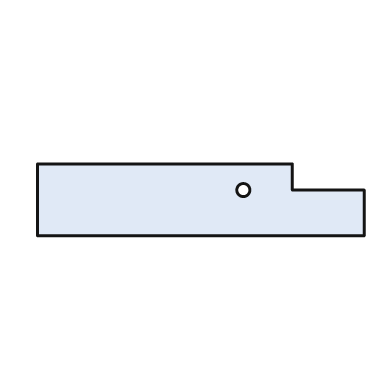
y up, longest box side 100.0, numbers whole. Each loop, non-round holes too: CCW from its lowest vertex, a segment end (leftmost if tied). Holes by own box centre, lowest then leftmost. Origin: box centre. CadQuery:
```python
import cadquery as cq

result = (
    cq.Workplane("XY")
    .moveTo(-50.0, -11.0)
    .lineTo(50.0, -11.0)
    .lineTo(50.0, 3.0)
    .lineTo(28.0, 3.0)
    .lineTo(28.0, 11.0)
    .lineTo(-50.0, 11.0)
    .close()
    .moveTo(13.0, 3.0)
    .circle(2.0)
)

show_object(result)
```